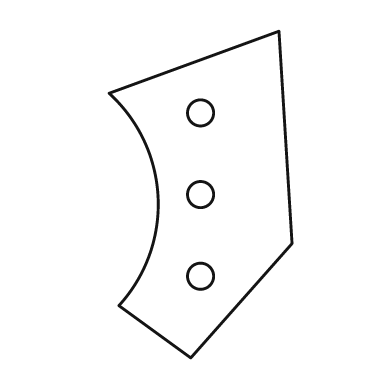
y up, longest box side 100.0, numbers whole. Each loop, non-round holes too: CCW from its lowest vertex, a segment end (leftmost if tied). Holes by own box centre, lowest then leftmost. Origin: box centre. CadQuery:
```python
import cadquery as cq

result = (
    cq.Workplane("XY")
    .moveTo(-3.0, -50.0)
    .lineTo(28.0, -15.0)
    .lineTo(24.0, 50.0)
    .lineTo(-28.0, 31.0)
    .threePointArc((-13.0, -1.0), (-25.0, -34.0))
    .close()
    .moveTo(0.0, -25.0)
    .circle(4.0)
    .moveTo(0.0, 0.0)
    .circle(4.0)
    .moveTo(0.0, 25.0)
    .circle(4.0)
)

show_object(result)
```